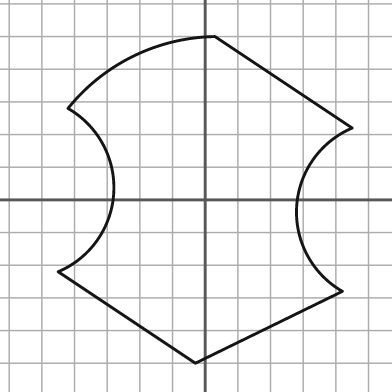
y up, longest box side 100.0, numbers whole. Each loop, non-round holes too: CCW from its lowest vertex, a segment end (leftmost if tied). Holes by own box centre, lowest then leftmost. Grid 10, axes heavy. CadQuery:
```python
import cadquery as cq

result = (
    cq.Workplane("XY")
    .moveTo(-3.0, -50.0)
    .lineTo(42.0, -28.0)
    .threePointArc((28.0, -2.0), (45.0, 22.0))
    .lineTo(3.0, 50.0)
    .threePointArc((-22.0, 44.0), (-42.0, 28.0))
    .threePointArc((-28.0, 2.0), (-45.0, -22.0))
    .close()
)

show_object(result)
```